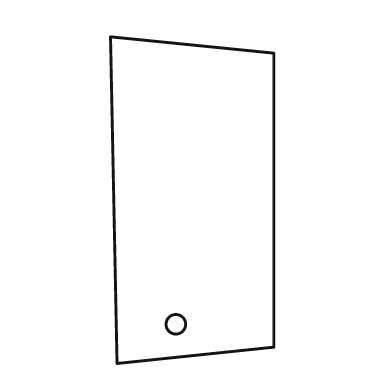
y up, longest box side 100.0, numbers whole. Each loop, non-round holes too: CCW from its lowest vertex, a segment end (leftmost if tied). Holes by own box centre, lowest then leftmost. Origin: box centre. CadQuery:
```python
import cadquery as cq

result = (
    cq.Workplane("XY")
    .moveTo(-23.0, -50.0)
    .lineTo(25.0, -45.0)
    .lineTo(25.0, 45.0)
    .lineTo(-25.0, 50.0)
    .close()
    .moveTo(-5.0, -38.0)
    .circle(3.0)
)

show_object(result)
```